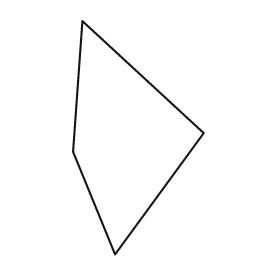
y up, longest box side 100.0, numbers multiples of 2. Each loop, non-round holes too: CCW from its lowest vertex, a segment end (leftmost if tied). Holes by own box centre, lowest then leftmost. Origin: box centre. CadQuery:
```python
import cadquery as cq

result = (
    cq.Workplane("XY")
    .moveTo(-10.0, -50.0)
    .lineTo(28.0, 2.0)
    .lineTo(-24.0, 50.0)
    .lineTo(-28.0, -6.0)
    .close()
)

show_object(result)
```